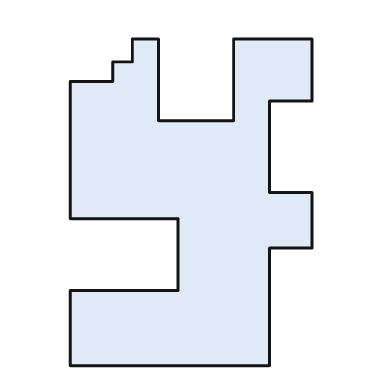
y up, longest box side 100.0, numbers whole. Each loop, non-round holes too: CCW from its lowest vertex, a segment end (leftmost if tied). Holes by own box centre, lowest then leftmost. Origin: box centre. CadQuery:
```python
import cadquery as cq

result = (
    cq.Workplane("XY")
    .moveTo(-37.0, -50.0)
    .lineTo(24.0, -50.0)
    .lineTo(24.0, -14.0)
    .lineTo(37.0, -14.0)
    .lineTo(37.0, 3.0)
    .lineTo(24.0, 3.0)
    .lineTo(24.0, 31.0)
    .lineTo(37.0, 31.0)
    .lineTo(37.0, 50.0)
    .lineTo(13.0, 50.0)
    .lineTo(13.0, 25.0)
    .lineTo(-10.0, 25.0)
    .lineTo(-10.0, 50.0)
    .lineTo(-18.0, 50.0)
    .lineTo(-18.0, 43.0)
    .lineTo(-24.0, 43.0)
    .lineTo(-24.0, 37.0)
    .lineTo(-37.0, 37.0)
    .lineTo(-37.0, -5.0)
    .lineTo(-4.0, -5.0)
    .lineTo(-4.0, -27.0)
    .lineTo(-37.0, -27.0)
    .close()
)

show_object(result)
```